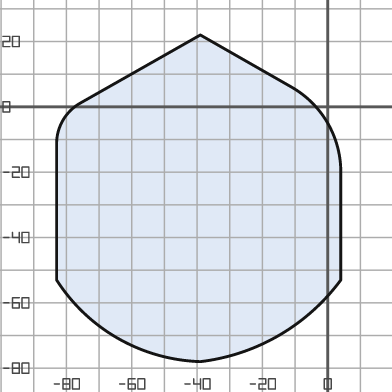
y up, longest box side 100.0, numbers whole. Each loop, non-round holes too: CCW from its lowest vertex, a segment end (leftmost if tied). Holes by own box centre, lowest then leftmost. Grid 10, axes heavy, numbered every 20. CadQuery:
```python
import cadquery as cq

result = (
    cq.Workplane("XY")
    .moveTo(-39.0, -78.0)
    .threePointArc((-15.0, -70.0), (4.0, -53.0))
    .lineTo(4.0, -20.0)
    .threePointArc((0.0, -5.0), (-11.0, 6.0))
    .lineTo(-39.0, 22.0)
    .lineTo(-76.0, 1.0)
    .threePointArc((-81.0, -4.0), (-83.0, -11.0))
    .lineTo(-83.0, -53.0)
    .threePointArc((-64.0, -71.0), (-39.0, -78.0))
    .close()
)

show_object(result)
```